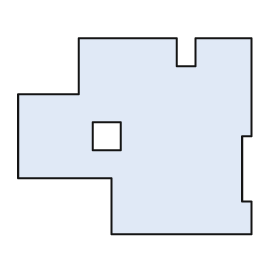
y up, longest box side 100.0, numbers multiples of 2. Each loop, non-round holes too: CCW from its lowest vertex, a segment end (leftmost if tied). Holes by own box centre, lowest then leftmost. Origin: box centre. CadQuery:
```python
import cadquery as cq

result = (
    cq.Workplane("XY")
    .moveTo(-10.0, -42.0)
    .lineTo(50.0, -42.0)
    .lineTo(50.0, -28.0)
    .lineTo(46.0, -28.0)
    .lineTo(46.0, 0.0)
    .lineTo(50.0, 0.0)
    .lineTo(50.0, 42.0)
    .lineTo(26.0, 42.0)
    .lineTo(26.0, 30.0)
    .lineTo(18.0, 30.0)
    .lineTo(18.0, 42.0)
    .lineTo(-24.0, 42.0)
    .lineTo(-24.0, 18.0)
    .lineTo(-50.0, 18.0)
    .lineTo(-50.0, -18.0)
    .lineTo(-10.0, -18.0)
    .close()
    .moveTo(-18.0, -6.0)
    .lineTo(-6.0, -6.0)
    .lineTo(-6.0, 6.0)
    .lineTo(-18.0, 6.0)
    .close()
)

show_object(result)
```